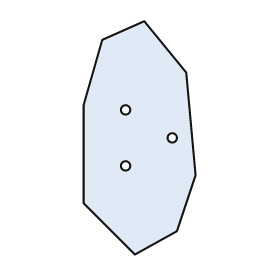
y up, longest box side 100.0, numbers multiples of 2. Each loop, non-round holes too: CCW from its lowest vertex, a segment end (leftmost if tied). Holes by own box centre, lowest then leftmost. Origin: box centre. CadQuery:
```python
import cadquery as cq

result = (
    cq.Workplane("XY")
    .moveTo(-2.0, -50.0)
    .lineTo(16.0, -40.0)
    .lineTo(24.0, -16.0)
    .lineTo(20.0, 28.0)
    .lineTo(2.0, 50.0)
    .lineTo(-16.0, 42.0)
    .lineTo(-24.0, 14.0)
    .lineTo(-24.0, -28.0)
    .close()
    .moveTo(-6.0, -12.0)
    .circle(2.0)
    .moveTo(14.0, 0.0)
    .circle(2.0)
    .moveTo(-6.0, 12.0)
    .circle(2.0)
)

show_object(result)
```